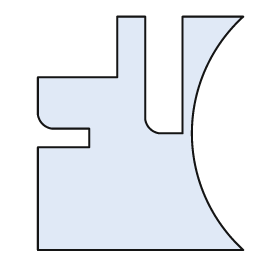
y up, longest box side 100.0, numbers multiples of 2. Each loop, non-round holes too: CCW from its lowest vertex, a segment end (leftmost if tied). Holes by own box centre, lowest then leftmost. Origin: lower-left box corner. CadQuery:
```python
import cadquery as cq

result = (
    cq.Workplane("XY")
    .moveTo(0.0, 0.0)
    .lineTo(88.0, 0.0)
    .threePointArc((66.0, 50.0), (88.0, 100.0))
    .lineTo(62.0, 100.0)
    .lineTo(62.0, 50.0)
    .lineTo(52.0, 50.0)
    .threePointArc((48.0, 52.0), (46.0, 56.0))
    .lineTo(46.0, 100.0)
    .lineTo(34.0, 100.0)
    .lineTo(34.0, 74.0)
    .lineTo(0.0, 74.0)
    .lineTo(0.0, 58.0)
    .threePointArc((2.0, 54.0), (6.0, 52.0))
    .lineTo(22.0, 52.0)
    .lineTo(22.0, 44.0)
    .lineTo(0.0, 44.0)
    .close()
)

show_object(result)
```